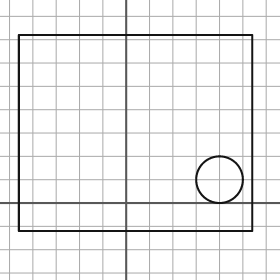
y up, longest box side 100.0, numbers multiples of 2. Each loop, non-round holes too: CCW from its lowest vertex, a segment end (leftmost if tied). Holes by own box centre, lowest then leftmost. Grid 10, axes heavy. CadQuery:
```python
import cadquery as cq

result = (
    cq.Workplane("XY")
    .moveTo(-46.0, -12.0)
    .lineTo(54.0, -12.0)
    .lineTo(54.0, 72.0)
    .lineTo(-46.0, 72.0)
    .close()
    .moveTo(40.0, 10.0)
    .circle(10.0)
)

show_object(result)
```